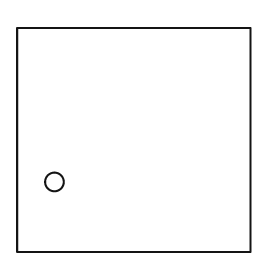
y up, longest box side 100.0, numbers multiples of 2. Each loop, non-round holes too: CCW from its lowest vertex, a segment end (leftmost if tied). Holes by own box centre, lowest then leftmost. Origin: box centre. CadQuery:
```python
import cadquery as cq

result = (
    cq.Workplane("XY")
    .moveTo(-50.0, -48.0)
    .lineTo(50.0, -48.0)
    .lineTo(50.0, 48.0)
    .lineTo(-50.0, 48.0)
    .close()
    .moveTo(-34.0, -18.0)
    .circle(4.0)
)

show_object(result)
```